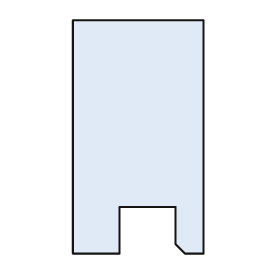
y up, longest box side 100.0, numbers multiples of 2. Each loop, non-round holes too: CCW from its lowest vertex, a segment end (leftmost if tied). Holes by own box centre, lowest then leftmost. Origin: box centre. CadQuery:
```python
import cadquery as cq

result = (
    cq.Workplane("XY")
    .moveTo(-28.0, -50.0)
    .lineTo(-8.0, -50.0)
    .lineTo(-8.0, -30.0)
    .lineTo(16.0, -30.0)
    .lineTo(16.0, -46.0)
    .lineTo(20.0, -50.0)
    .lineTo(28.0, -50.0)
    .lineTo(28.0, 50.0)
    .lineTo(-28.0, 50.0)
    .close()
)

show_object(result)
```